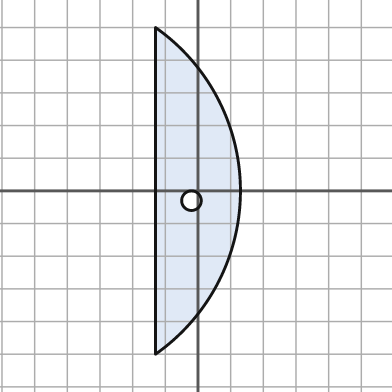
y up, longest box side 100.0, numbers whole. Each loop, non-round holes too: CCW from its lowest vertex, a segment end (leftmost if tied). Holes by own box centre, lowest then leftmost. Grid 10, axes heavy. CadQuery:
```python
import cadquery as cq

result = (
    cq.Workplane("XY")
    .moveTo(-13.0, -50.0)
    .threePointArc((13.0, 0.0), (-13.0, 50.0))
    .close()
    .moveTo(-2.0, -3.0)
    .circle(3.0)
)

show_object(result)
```